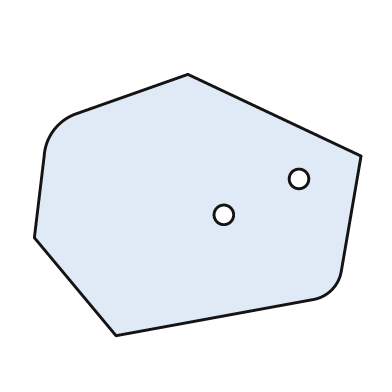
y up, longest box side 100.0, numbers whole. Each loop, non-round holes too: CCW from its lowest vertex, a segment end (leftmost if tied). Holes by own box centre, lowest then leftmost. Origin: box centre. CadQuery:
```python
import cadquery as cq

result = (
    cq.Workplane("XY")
    .moveTo(-25.0, -40.0)
    .lineTo(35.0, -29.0)
    .threePointArc((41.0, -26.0), (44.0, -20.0))
    .lineTo(50.0, 15.0)
    .lineTo(-3.0, 40.0)
    .lineTo(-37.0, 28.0)
    .threePointArc((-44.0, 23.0), (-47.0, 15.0))
    .lineTo(-50.0, -10.0)
    .close()
    .moveTo(8.0, -3.0)
    .circle(3.0)
    .moveTo(31.0, 8.0)
    .circle(3.0)
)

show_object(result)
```